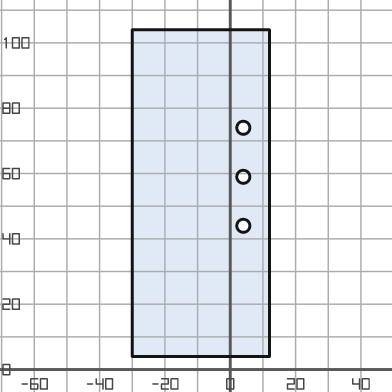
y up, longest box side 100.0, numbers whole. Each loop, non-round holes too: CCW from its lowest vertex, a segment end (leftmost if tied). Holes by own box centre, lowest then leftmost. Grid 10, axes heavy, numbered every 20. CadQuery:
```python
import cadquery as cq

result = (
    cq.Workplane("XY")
    .moveTo(-30.0, 4.0)
    .lineTo(12.0, 4.0)
    .lineTo(12.0, 104.0)
    .lineTo(-30.0, 104.0)
    .close()
    .moveTo(4.0, 44.0)
    .circle(2.0)
    .moveTo(4.0, 59.0)
    .circle(2.0)
    .moveTo(4.0, 74.0)
    .circle(2.0)
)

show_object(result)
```